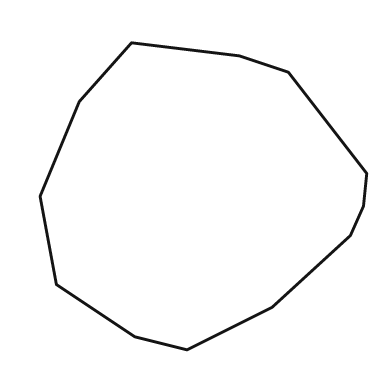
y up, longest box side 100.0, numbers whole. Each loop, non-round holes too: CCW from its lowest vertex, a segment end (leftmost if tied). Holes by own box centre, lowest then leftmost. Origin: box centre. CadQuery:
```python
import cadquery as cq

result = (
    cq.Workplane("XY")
    .moveTo(-5.0, -47.0)
    .lineTo(21.0, -34.0)
    .lineTo(45.0, -12.0)
    .lineTo(49.0, -3.0)
    .lineTo(50.0, 7.0)
    .lineTo(26.0, 38.0)
    .lineTo(11.0, 43.0)
    .lineTo(-22.0, 47.0)
    .lineTo(-38.0, 29.0)
    .lineTo(-50.0, 0.0)
    .lineTo(-45.0, -27.0)
    .lineTo(-21.0, -43.0)
    .close()
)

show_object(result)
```